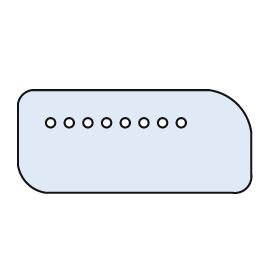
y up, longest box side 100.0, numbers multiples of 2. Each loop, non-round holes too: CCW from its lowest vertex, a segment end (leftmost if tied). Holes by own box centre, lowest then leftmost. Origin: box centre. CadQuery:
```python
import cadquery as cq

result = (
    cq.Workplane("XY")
    .moveTo(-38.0, -22.0)
    .lineTo(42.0, -22.0)
    .threePointArc((48.0, -20.0), (50.0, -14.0))
    .lineTo(50.0, 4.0)
    .threePointArc((44.0, 16.0), (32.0, 22.0))
    .lineTo(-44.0, 22.0)
    .threePointArc((-48.0, 20.0), (-50.0, 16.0))
    .lineTo(-50.0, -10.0)
    .threePointArc((-46.0, -18.0), (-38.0, -22.0))
    .close()
    .moveTo(-36.0, 8.0)
    .circle(2.0)
    .moveTo(-28.0, 8.0)
    .circle(2.0)
    .moveTo(-20.0, 8.0)
    .circle(2.0)
    .moveTo(-12.0, 8.0)
    .circle(2.0)
    .moveTo(-4.0, 8.0)
    .circle(2.0)
    .moveTo(4.0, 8.0)
    .circle(2.0)
    .moveTo(12.0, 8.0)
    .circle(2.0)
    .moveTo(20.0, 8.0)
    .circle(2.0)
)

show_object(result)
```